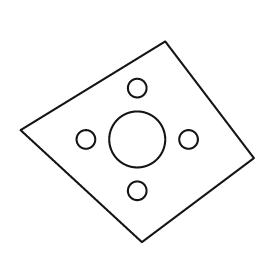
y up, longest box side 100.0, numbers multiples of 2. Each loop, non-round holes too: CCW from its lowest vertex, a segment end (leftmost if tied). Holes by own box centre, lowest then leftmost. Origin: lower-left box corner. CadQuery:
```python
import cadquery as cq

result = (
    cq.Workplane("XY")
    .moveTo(52.0, 0.0)
    .lineTo(100.0, 36.0)
    .lineTo(62.0, 86.0)
    .lineTo(0.0, 48.0)
    .close()
    .moveTo(50.0, 22.0)
    .circle(4.0)
    .moveTo(28.0, 44.0)
    .circle(4.0)
    .moveTo(50.0, 44.0)
    .circle(12.0)
    .moveTo(72.0, 44.0)
    .circle(4.0)
    .moveTo(50.0, 66.0)
    .circle(4.0)
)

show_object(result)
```